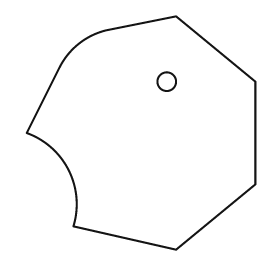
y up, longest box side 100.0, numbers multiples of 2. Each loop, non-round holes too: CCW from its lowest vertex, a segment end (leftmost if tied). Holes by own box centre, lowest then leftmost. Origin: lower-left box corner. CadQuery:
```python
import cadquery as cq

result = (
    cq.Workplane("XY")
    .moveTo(64.0, 0.0)
    .lineTo(98.0, 28.0)
    .lineTo(98.0, 72.0)
    .lineTo(64.0, 100.0)
    .lineTo(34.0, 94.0)
    .threePointArc((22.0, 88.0), (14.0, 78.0))
    .lineTo(0.0, 50.0)
    .threePointArc((18.0, 34.0), (20.0, 10.0))
    .close()
    .moveTo(60.0, 72.0)
    .circle(4.0)
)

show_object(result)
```